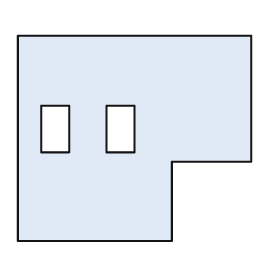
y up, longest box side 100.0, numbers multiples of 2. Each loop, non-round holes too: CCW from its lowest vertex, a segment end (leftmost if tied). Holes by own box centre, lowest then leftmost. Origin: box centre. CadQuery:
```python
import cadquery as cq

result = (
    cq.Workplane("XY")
    .moveTo(-50.0, -44.0)
    .lineTo(16.0, -44.0)
    .lineTo(16.0, -10.0)
    .lineTo(50.0, -10.0)
    .lineTo(50.0, 44.0)
    .lineTo(-50.0, 44.0)
    .close()
    .moveTo(-40.0, -6.0)
    .lineTo(-28.0, -6.0)
    .lineTo(-28.0, 14.0)
    .lineTo(-40.0, 14.0)
    .close()
    .moveTo(-12.0, -6.0)
    .lineTo(0.0, -6.0)
    .lineTo(0.0, 14.0)
    .lineTo(-12.0, 14.0)
    .close()
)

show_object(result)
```